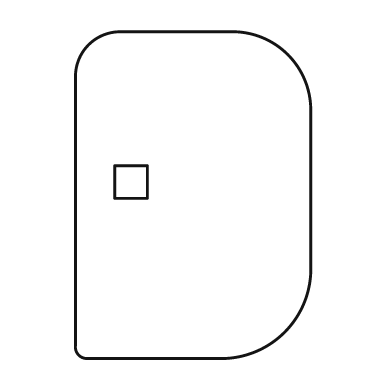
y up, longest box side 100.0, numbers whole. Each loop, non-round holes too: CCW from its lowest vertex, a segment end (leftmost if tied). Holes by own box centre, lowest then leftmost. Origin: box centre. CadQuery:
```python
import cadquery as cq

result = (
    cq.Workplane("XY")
    .moveTo(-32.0, -50.0)
    .lineTo(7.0, -50.0)
    .threePointArc((28.0, -42.0), (36.0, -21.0))
    .lineTo(36.0, 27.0)
    .threePointArc((29.0, 43.0), (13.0, 50.0))
    .lineTo(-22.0, 50.0)
    .threePointArc((-32.0, 46.0), (-36.0, 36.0))
    .lineTo(-36.0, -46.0)
    .threePointArc((-35.0, -49.0), (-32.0, -50.0))
    .close()
    .moveTo(-24.0, -1.0)
    .lineTo(-14.0, -1.0)
    .lineTo(-14.0, 9.0)
    .lineTo(-24.0, 9.0)
    .close()
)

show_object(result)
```